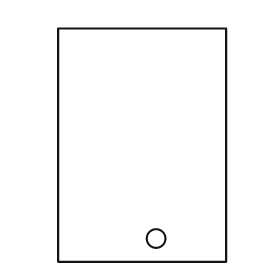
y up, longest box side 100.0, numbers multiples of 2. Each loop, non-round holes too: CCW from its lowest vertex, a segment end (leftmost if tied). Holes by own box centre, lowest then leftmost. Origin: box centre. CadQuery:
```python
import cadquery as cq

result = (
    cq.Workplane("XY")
    .moveTo(-36.0, -50.0)
    .lineTo(36.0, -50.0)
    .lineTo(36.0, 50.0)
    .lineTo(-36.0, 50.0)
    .close()
    .moveTo(6.0, -40.0)
    .circle(4.0)
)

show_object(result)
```